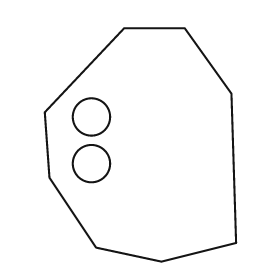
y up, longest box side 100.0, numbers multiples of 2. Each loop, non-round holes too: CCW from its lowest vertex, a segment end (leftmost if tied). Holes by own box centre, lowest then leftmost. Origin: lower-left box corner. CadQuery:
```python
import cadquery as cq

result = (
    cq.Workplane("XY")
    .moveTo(50.0, 0.0)
    .lineTo(82.0, 8.0)
    .lineTo(80.0, 72.0)
    .lineTo(60.0, 100.0)
    .lineTo(34.0, 100.0)
    .lineTo(0.0, 64.0)
    .lineTo(2.0, 36.0)
    .lineTo(22.0, 6.0)
    .close()
    .moveTo(20.0, 42.0)
    .circle(8.0)
    .moveTo(20.0, 62.0)
    .circle(8.0)
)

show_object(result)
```